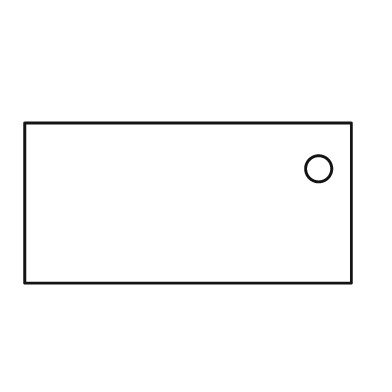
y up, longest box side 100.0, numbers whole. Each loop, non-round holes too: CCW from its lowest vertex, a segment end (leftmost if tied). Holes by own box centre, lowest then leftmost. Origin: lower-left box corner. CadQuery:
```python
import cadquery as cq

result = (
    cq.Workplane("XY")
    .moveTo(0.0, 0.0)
    .lineTo(100.0, 0.0)
    .lineTo(100.0, 49.0)
    .lineTo(0.0, 49.0)
    .close()
    .moveTo(90.0, 35.0)
    .circle(4.0)
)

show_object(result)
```